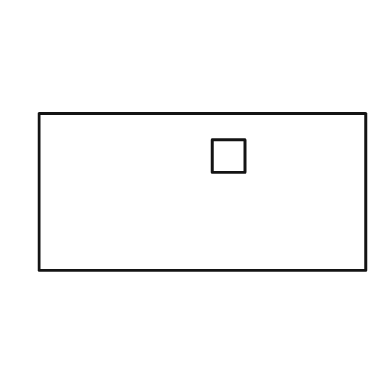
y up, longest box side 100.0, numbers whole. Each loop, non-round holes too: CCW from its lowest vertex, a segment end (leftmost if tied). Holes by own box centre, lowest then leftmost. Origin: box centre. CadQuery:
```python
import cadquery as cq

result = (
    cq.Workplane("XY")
    .moveTo(-50.0, -24.0)
    .lineTo(50.0, -24.0)
    .lineTo(50.0, 24.0)
    .lineTo(-50.0, 24.0)
    .close()
    .moveTo(3.0, 6.0)
    .lineTo(13.0, 6.0)
    .lineTo(13.0, 16.0)
    .lineTo(3.0, 16.0)
    .close()
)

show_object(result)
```